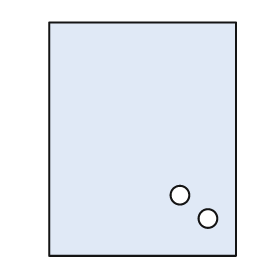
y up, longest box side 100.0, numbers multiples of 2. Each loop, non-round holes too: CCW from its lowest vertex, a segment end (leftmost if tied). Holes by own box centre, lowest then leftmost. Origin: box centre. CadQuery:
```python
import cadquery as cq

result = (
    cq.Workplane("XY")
    .moveTo(-40.0, -50.0)
    .lineTo(40.0, -50.0)
    .lineTo(40.0, 50.0)
    .lineTo(-40.0, 50.0)
    .close()
    .moveTo(28.0, -34.0)
    .circle(4.0)
    .moveTo(16.0, -24.0)
    .circle(4.0)
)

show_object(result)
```